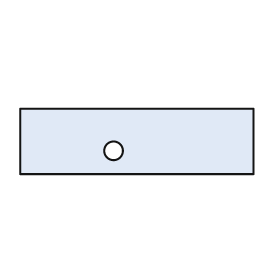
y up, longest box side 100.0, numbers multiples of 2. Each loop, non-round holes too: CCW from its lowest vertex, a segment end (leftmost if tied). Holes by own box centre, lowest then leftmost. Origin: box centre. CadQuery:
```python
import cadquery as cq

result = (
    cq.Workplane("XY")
    .moveTo(-50.0, -14.0)
    .lineTo(50.0, -14.0)
    .lineTo(50.0, 14.0)
    .lineTo(-50.0, 14.0)
    .close()
    .moveTo(-10.0, -4.0)
    .circle(4.0)
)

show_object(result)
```